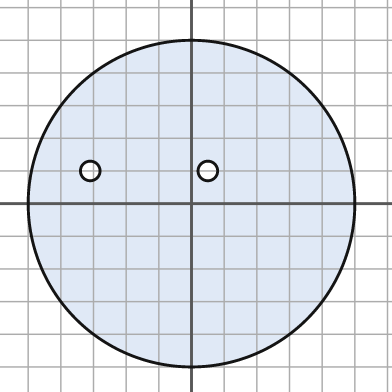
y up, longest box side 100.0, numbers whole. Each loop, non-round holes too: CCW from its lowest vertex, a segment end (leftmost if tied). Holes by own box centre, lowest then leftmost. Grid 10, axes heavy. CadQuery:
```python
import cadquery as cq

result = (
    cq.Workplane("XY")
    .moveTo(0.0, 0.0)
    .circle(50.0)
    .moveTo(-31.0, 10.0)
    .circle(3.0)
    .moveTo(5.0, 10.0)
    .circle(3.0)
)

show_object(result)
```